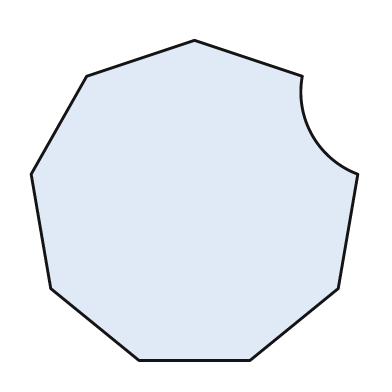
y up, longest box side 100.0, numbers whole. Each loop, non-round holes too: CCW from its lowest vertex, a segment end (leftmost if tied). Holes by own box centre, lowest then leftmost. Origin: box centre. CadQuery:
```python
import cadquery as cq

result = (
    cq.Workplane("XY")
    .moveTo(-17.0, -49.0)
    .lineTo(17.0, -49.0)
    .lineTo(44.0, -27.0)
    .lineTo(50.0, 8.0)
    .threePointArc((36.0, 20.0), (33.0, 38.0))
    .lineTo(0.0, 49.0)
    .lineTo(-33.0, 38.0)
    .lineTo(-50.0, 8.0)
    .lineTo(-44.0, -27.0)
    .close()
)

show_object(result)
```